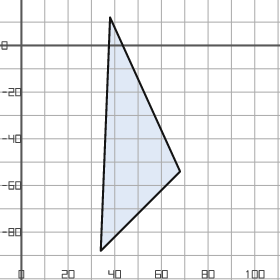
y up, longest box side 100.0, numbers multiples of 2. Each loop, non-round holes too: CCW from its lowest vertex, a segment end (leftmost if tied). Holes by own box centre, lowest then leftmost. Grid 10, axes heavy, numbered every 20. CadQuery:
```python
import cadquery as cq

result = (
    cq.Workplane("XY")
    .moveTo(34.0, -88.0)
    .lineTo(68.0, -54.0)
    .lineTo(38.0, 12.0)
    .close()
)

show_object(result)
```